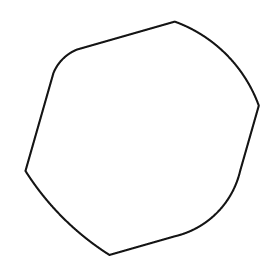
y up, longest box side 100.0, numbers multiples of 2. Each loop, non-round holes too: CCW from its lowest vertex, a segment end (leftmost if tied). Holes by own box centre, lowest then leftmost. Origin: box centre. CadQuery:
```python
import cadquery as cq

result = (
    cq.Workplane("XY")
    .moveTo(-14.0, -50.0)
    .lineTo(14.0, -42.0)
    .threePointArc((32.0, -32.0), (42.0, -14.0))
    .lineTo(50.0, 14.0)
    .threePointArc((36.0, 36.0), (14.0, 50.0))
    .lineTo(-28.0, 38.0)
    .threePointArc((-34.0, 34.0), (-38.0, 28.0))
    .lineTo(-50.0, -14.0)
    .threePointArc((-34.0, -34.0), (-14.0, -50.0))
    .close()
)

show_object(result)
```